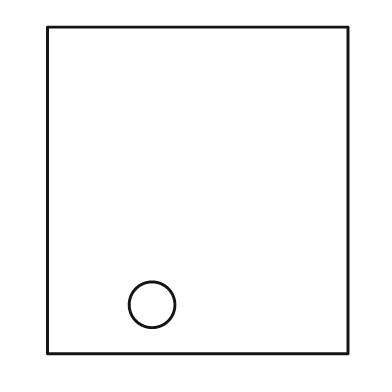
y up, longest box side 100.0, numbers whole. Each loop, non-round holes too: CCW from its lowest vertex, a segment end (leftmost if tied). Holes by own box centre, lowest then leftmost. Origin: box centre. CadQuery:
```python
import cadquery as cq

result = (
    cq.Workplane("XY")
    .moveTo(-46.0, -50.0)
    .lineTo(46.0, -50.0)
    .lineTo(46.0, 50.0)
    .lineTo(-46.0, 50.0)
    .close()
    .moveTo(-14.0, -35.0)
    .circle(7.0)
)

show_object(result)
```